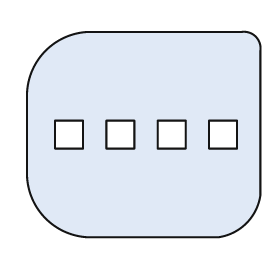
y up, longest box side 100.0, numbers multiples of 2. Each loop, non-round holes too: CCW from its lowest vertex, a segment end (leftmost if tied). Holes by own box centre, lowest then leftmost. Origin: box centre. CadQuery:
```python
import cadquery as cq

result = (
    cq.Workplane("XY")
    .moveTo(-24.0, -44.0)
    .lineTo(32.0, -44.0)
    .threePointArc((44.0, -38.0), (50.0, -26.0))
    .lineTo(50.0, 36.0)
    .threePointArc((48.0, 42.0), (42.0, 44.0))
    .lineTo(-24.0, 44.0)
    .threePointArc((-42.0, 36.0), (-50.0, 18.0))
    .lineTo(-50.0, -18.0)
    .threePointArc((-42.0, -36.0), (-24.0, -44.0))
    .close()
    .moveTo(-38.0, -6.0)
    .lineTo(-26.0, -6.0)
    .lineTo(-26.0, 6.0)
    .lineTo(-38.0, 6.0)
    .close()
    .moveTo(-16.0, -6.0)
    .lineTo(-4.0, -6.0)
    .lineTo(-4.0, 6.0)
    .lineTo(-16.0, 6.0)
    .close()
    .moveTo(6.0, -6.0)
    .lineTo(18.0, -6.0)
    .lineTo(18.0, 6.0)
    .lineTo(6.0, 6.0)
    .close()
    .moveTo(28.0, -6.0)
    .lineTo(40.0, -6.0)
    .lineTo(40.0, 6.0)
    .lineTo(28.0, 6.0)
    .close()
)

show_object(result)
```